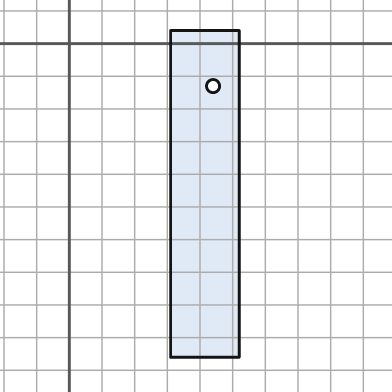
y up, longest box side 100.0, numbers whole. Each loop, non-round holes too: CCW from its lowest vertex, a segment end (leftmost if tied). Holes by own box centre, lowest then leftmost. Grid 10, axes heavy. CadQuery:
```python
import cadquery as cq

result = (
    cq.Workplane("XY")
    .moveTo(31.0, -96.0)
    .lineTo(52.0, -96.0)
    .lineTo(52.0, 4.0)
    .lineTo(31.0, 4.0)
    .close()
    .moveTo(44.0, -13.0)
    .circle(2.0)
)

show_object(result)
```